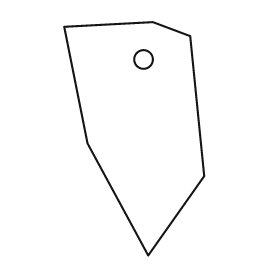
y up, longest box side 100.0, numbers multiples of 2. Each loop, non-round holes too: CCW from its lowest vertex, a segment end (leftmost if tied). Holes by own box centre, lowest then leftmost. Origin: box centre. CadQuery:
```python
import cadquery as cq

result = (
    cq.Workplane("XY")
    .moveTo(6.0, -50.0)
    .lineTo(30.0, -16.0)
    .lineTo(24.0, 44.0)
    .lineTo(8.0, 50.0)
    .lineTo(-30.0, 48.0)
    .lineTo(-20.0, -2.0)
    .close()
    .moveTo(4.0, 34.0)
    .circle(4.0)
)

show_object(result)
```